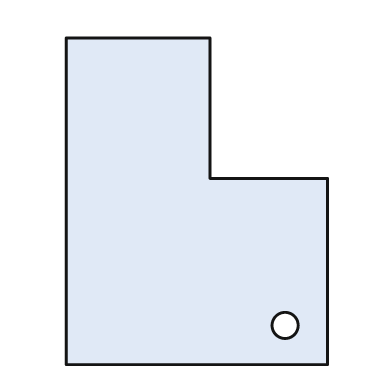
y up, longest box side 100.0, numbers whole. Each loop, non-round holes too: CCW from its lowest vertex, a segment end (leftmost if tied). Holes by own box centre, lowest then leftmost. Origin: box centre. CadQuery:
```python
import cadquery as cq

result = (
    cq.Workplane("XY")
    .moveTo(-40.0, -50.0)
    .lineTo(40.0, -50.0)
    .lineTo(40.0, 7.0)
    .lineTo(4.0, 7.0)
    .lineTo(4.0, 50.0)
    .lineTo(-40.0, 50.0)
    .close()
    .moveTo(27.0, -38.0)
    .circle(4.0)
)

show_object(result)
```